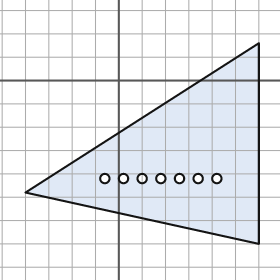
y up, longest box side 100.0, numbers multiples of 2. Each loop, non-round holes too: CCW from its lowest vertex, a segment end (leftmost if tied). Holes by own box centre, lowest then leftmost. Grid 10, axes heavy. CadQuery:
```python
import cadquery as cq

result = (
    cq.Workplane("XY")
    .moveTo(60.0, -70.0)
    .lineTo(60.0, 16.0)
    .lineTo(-40.0, -48.0)
    .close()
    .moveTo(-6.0, -42.0)
    .circle(2.0)
    .moveTo(2.0, -42.0)
    .circle(2.0)
    .moveTo(10.0, -42.0)
    .circle(2.0)
    .moveTo(18.0, -42.0)
    .circle(2.0)
    .moveTo(26.0, -42.0)
    .circle(2.0)
    .moveTo(34.0, -42.0)
    .circle(2.0)
    .moveTo(42.0, -42.0)
    .circle(2.0)
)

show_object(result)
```